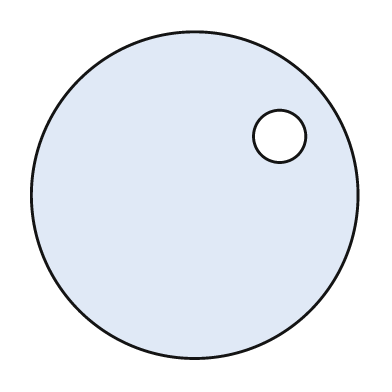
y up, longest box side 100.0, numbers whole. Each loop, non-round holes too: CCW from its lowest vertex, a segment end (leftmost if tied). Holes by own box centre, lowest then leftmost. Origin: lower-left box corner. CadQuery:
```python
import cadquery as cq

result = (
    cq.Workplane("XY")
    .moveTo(50.0, 50.0)
    .circle(50.0)
    .moveTo(76.0, 68.0)
    .circle(8.0)
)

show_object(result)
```